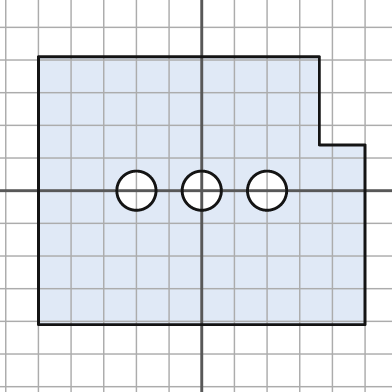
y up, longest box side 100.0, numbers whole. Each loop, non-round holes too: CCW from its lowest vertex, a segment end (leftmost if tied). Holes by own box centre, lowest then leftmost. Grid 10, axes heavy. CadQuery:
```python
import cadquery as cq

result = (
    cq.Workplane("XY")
    .moveTo(-50.0, -41.0)
    .lineTo(50.0, -41.0)
    .lineTo(50.0, 14.0)
    .lineTo(36.0, 14.0)
    .lineTo(36.0, 41.0)
    .lineTo(-50.0, 41.0)
    .close()
    .moveTo(-20.0, 0.0)
    .circle(6.0)
    .moveTo(0.0, 0.0)
    .circle(6.0)
    .moveTo(20.0, 0.0)
    .circle(6.0)
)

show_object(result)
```